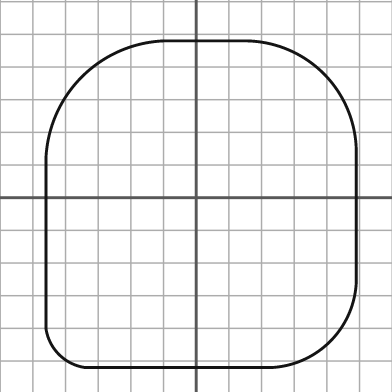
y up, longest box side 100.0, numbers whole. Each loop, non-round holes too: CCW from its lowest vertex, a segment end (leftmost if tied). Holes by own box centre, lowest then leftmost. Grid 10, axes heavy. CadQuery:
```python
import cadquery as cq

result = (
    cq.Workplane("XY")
    .moveTo(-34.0, -52.0)
    .lineTo(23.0, -52.0)
    .threePointArc((41.0, -44.0), (49.0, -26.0))
    .lineTo(49.0, 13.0)
    .threePointArc((39.0, 38.0), (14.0, 48.0))
    .lineTo(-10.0, 48.0)
    .threePointArc((-35.0, 37.0), (-46.0, 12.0))
    .lineTo(-46.0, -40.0)
    .threePointArc((-42.0, -48.0), (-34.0, -52.0))
    .close()
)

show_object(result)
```